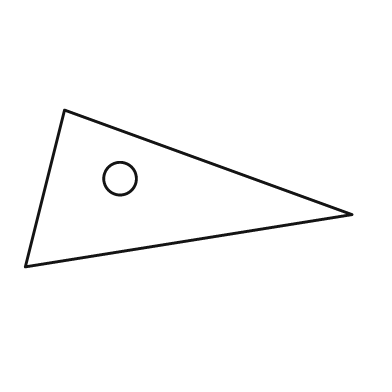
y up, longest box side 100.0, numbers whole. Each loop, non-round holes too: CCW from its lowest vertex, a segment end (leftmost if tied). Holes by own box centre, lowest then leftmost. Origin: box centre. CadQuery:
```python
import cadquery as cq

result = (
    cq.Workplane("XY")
    .moveTo(-50.0, -24.0)
    .lineTo(50.0, -8.0)
    .lineTo(-38.0, 24.0)
    .close()
    .moveTo(-21.0, 3.0)
    .circle(5.0)
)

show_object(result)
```